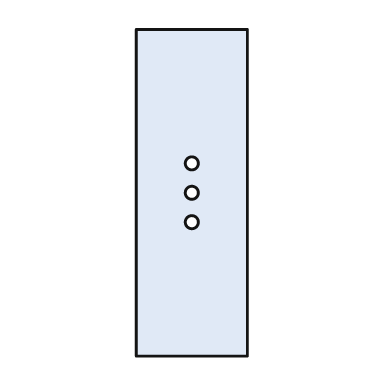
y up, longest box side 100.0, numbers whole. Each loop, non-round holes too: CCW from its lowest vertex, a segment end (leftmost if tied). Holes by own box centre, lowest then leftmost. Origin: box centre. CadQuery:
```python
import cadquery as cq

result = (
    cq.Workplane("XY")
    .moveTo(-17.0, -50.0)
    .lineTo(17.0, -50.0)
    .lineTo(17.0, 50.0)
    .lineTo(-17.0, 50.0)
    .close()
    .moveTo(0.0, -9.0)
    .circle(2.0)
    .moveTo(0.0, 0.0)
    .circle(2.0)
    .moveTo(0.0, 9.0)
    .circle(2.0)
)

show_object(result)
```